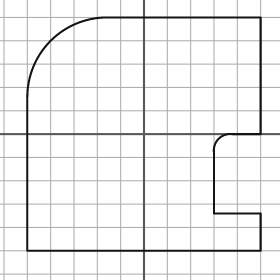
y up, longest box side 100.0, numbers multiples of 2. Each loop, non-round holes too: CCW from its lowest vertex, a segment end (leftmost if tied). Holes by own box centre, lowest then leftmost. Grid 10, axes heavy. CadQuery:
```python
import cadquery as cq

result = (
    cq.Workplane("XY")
    .moveTo(-50.0, -50.0)
    .lineTo(50.0, -50.0)
    .lineTo(50.0, -34.0)
    .lineTo(30.0, -34.0)
    .lineTo(30.0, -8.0)
    .threePointArc((32.0, -2.0), (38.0, 0.0))
    .lineTo(50.0, 0.0)
    .lineTo(50.0, 50.0)
    .lineTo(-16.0, 50.0)
    .threePointArc((-40.0, 40.0), (-50.0, 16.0))
    .close()
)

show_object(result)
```